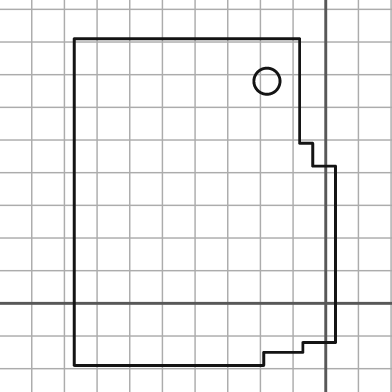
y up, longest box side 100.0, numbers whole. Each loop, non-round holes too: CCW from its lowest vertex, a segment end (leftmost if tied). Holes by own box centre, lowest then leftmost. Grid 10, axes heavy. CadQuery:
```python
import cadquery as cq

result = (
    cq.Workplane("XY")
    .moveTo(-77.0, -19.0)
    .lineTo(-19.0, -19.0)
    .lineTo(-19.0, -15.0)
    .lineTo(-7.0, -15.0)
    .lineTo(-7.0, -12.0)
    .lineTo(3.0, -12.0)
    .lineTo(3.0, 42.0)
    .lineTo(-4.0, 42.0)
    .lineTo(-4.0, 49.0)
    .lineTo(-8.0, 49.0)
    .lineTo(-8.0, 81.0)
    .lineTo(-77.0, 81.0)
    .close()
    .moveTo(-18.0, 68.0)
    .circle(4.0)
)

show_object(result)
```